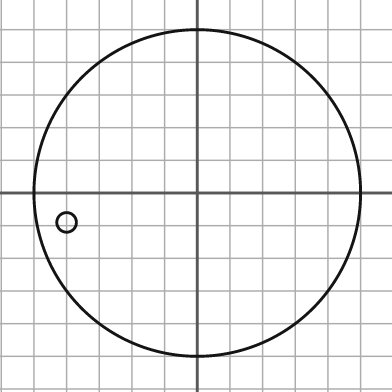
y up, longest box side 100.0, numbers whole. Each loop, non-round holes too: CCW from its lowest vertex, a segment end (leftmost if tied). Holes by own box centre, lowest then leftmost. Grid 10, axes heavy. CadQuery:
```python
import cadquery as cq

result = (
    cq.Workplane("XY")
    .moveTo(0.0, 0.0)
    .circle(50.0)
    .moveTo(-40.0, -9.0)
    .circle(3.0)
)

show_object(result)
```